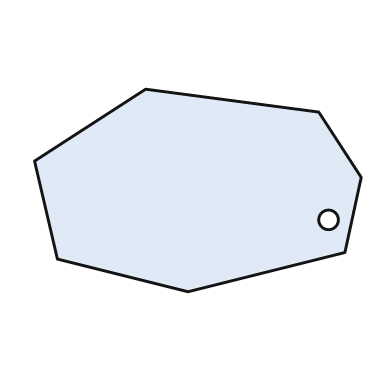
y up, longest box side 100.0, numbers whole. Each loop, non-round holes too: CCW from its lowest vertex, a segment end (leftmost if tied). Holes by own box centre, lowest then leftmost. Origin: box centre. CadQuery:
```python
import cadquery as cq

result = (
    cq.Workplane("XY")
    .moveTo(-3.0, -31.0)
    .lineTo(45.0, -19.0)
    .lineTo(50.0, 4.0)
    .lineTo(37.0, 24.0)
    .lineTo(-16.0, 31.0)
    .lineTo(-50.0, 9.0)
    .lineTo(-43.0, -21.0)
    .close()
    .moveTo(40.0, -9.0)
    .circle(3.0)
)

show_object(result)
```